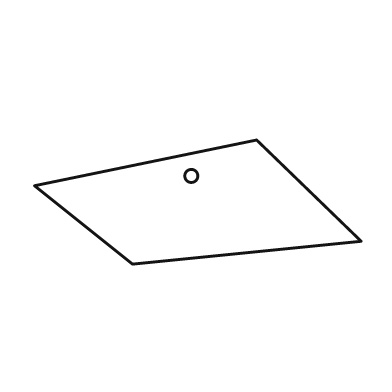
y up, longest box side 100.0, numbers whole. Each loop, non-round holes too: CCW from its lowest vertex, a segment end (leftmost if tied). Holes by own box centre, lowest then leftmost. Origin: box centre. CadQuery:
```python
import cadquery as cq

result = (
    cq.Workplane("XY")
    .moveTo(-20.0, -19.0)
    .lineTo(50.0, -12.0)
    .lineTo(18.0, 19.0)
    .lineTo(-50.0, 5.0)
    .close()
    .moveTo(-2.0, 8.0)
    .circle(2.0)
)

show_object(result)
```